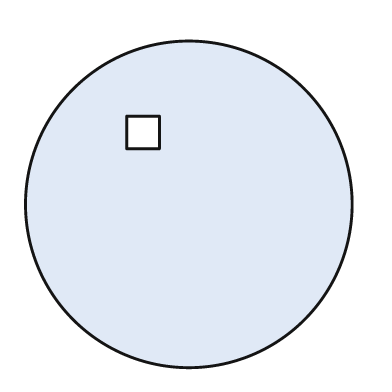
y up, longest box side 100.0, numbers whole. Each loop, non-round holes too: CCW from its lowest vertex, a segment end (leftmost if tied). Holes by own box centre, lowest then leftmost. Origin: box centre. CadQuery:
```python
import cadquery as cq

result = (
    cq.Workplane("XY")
    .moveTo(0.0, 0.0)
    .circle(50.0)
    .moveTo(-19.0, 17.0)
    .lineTo(-9.0, 17.0)
    .lineTo(-9.0, 27.0)
    .lineTo(-19.0, 27.0)
    .close()
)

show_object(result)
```